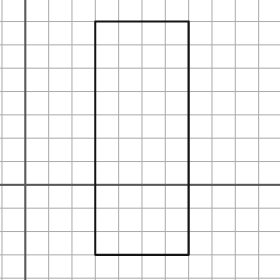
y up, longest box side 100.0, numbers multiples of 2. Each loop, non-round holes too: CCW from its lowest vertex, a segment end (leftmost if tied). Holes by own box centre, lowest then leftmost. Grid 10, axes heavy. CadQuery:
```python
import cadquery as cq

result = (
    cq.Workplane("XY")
    .moveTo(30.0, -30.0)
    .lineTo(70.0, -30.0)
    .lineTo(70.0, 70.0)
    .lineTo(30.0, 70.0)
    .close()
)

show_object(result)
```